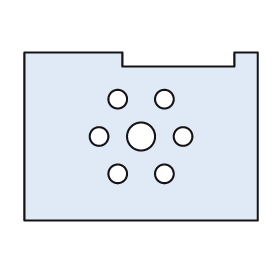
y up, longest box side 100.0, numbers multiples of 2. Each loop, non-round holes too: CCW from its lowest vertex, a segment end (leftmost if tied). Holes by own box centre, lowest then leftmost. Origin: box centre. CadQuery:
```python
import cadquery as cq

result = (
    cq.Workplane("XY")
    .moveTo(-50.0, -36.0)
    .lineTo(50.0, -36.0)
    .lineTo(50.0, 36.0)
    .lineTo(40.0, 36.0)
    .lineTo(40.0, 30.0)
    .lineTo(-8.0, 30.0)
    .lineTo(-8.0, 36.0)
    .lineTo(-50.0, 36.0)
    .close()
    .moveTo(-10.0, -16.0)
    .circle(4.0)
    .moveTo(10.0, -16.0)
    .circle(4.0)
    .moveTo(-18.0, 0.0)
    .circle(4.0)
    .moveTo(0.0, 0.0)
    .circle(6.0)
    .moveTo(18.0, 0.0)
    .circle(4.0)
    .moveTo(-10.0, 16.0)
    .circle(4.0)
    .moveTo(10.0, 16.0)
    .circle(4.0)
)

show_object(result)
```